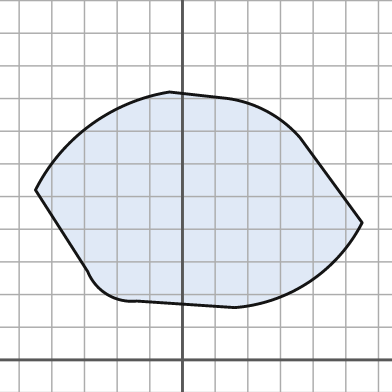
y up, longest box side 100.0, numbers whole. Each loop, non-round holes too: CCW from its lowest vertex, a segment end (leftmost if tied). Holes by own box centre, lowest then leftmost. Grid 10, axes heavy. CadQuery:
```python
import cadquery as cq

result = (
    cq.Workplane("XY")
    .moveTo(16.0, 16.0)
    .threePointArc((39.0, 24.0), (55.0, 42.0))
    .lineTo(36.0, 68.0)
    .threePointArc((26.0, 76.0), (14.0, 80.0))
    .lineTo(-4.0, 82.0)
    .threePointArc((-28.0, 72.0), (-45.0, 52.0))
    .lineTo(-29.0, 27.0)
    .threePointArc((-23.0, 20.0), (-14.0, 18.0))
    .close()
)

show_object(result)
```